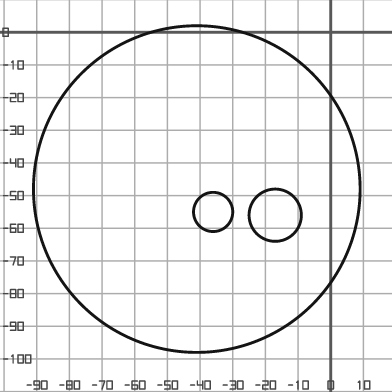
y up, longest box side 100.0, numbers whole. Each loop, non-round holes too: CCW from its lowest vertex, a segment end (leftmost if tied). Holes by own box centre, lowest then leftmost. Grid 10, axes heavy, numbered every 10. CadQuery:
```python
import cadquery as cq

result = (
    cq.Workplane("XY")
    .moveTo(-41.0, -48.0)
    .circle(50.0)
    .moveTo(-17.0, -56.0)
    .circle(8.0)
    .moveTo(-36.0, -55.0)
    .circle(6.0)
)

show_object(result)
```